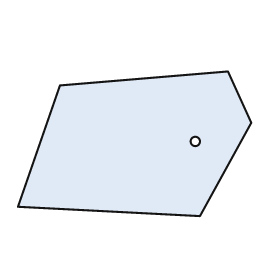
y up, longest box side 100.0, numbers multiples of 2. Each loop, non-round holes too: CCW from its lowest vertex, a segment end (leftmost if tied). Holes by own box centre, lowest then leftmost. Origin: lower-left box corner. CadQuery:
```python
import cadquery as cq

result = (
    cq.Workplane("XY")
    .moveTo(78.0, 0.0)
    .lineTo(100.0, 40.0)
    .lineTo(90.0, 62.0)
    .lineTo(18.0, 56.0)
    .lineTo(0.0, 4.0)
    .close()
    .moveTo(76.0, 32.0)
    .circle(2.0)
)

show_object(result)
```